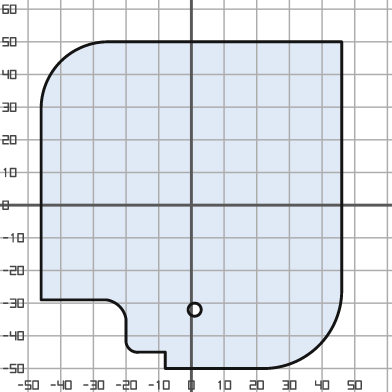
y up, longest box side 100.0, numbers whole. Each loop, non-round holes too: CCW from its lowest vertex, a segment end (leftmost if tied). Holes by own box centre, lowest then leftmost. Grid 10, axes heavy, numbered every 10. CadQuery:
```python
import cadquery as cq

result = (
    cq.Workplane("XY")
    .moveTo(-8.0, -50.0)
    .lineTo(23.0, -50.0)
    .threePointArc((39.0, -43.0), (46.0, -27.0))
    .lineTo(46.0, 50.0)
    .lineTo(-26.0, 50.0)
    .threePointArc((-40.0, 44.0), (-46.0, 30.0))
    .lineTo(-46.0, -29.0)
    .lineTo(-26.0, -29.0)
    .threePointArc((-22.0, -31.0), (-20.0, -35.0))
    .lineTo(-20.0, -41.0)
    .threePointArc((-19.0, -44.0), (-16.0, -45.0))
    .lineTo(-8.0, -45.0)
    .close()
    .moveTo(1.0, -32.0)
    .circle(2.0)
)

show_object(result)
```